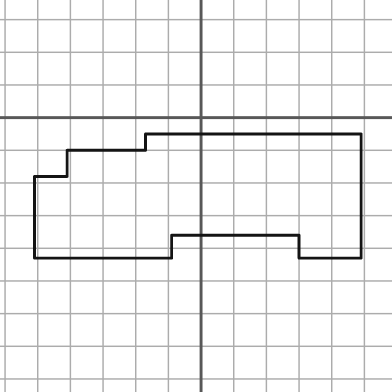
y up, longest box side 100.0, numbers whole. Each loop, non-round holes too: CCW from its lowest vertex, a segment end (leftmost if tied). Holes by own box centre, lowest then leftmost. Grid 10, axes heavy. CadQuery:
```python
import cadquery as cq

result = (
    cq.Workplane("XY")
    .moveTo(-51.0, -43.0)
    .lineTo(-9.0, -43.0)
    .lineTo(-9.0, -36.0)
    .lineTo(30.0, -36.0)
    .lineTo(30.0, -43.0)
    .lineTo(49.0, -43.0)
    .lineTo(49.0, -5.0)
    .lineTo(-17.0, -5.0)
    .lineTo(-17.0, -10.0)
    .lineTo(-41.0, -10.0)
    .lineTo(-41.0, -18.0)
    .lineTo(-51.0, -18.0)
    .close()
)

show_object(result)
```